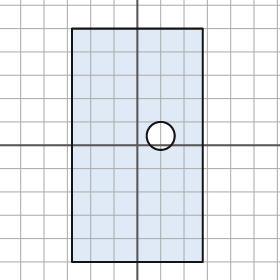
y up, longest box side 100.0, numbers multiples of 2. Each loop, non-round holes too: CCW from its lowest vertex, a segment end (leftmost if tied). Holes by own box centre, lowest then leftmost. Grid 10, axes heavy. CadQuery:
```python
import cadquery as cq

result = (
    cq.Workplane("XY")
    .moveTo(-28.0, -50.0)
    .lineTo(28.0, -50.0)
    .lineTo(28.0, 50.0)
    .lineTo(-28.0, 50.0)
    .close()
    .moveTo(10.0, 4.0)
    .circle(6.0)
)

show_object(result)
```